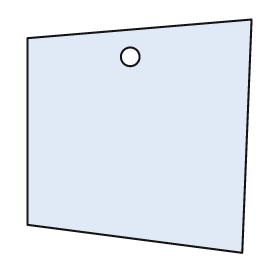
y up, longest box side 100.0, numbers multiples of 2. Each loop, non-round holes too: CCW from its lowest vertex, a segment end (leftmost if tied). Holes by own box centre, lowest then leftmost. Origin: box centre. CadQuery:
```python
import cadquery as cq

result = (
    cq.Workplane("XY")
    .moveTo(44.0, -50.0)
    .lineTo(48.0, 50.0)
    .lineTo(-48.0, 42.0)
    .lineTo(-48.0, -38.0)
    .close()
    .moveTo(-4.0, 34.0)
    .circle(4.0)
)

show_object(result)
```